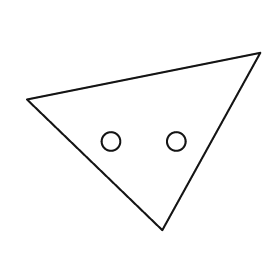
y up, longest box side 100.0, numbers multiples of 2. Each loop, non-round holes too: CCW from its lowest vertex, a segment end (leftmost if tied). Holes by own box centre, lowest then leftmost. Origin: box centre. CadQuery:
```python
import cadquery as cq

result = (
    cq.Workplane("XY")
    .moveTo(8.0, -38.0)
    .lineTo(50.0, 38.0)
    .lineTo(-50.0, 18.0)
    .close()
    .moveTo(-14.0, 0.0)
    .circle(4.0)
    .moveTo(14.0, 0.0)
    .circle(4.0)
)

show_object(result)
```